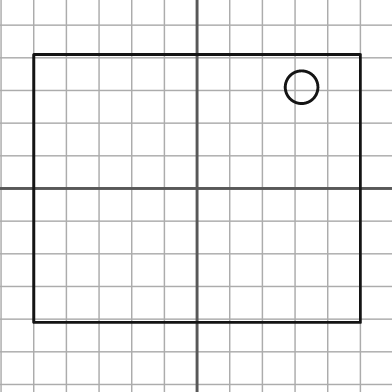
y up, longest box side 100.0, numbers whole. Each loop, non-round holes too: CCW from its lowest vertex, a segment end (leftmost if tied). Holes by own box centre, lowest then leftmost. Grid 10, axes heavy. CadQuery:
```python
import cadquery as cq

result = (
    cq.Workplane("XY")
    .moveTo(-50.0, -41.0)
    .lineTo(50.0, -41.0)
    .lineTo(50.0, 41.0)
    .lineTo(-50.0, 41.0)
    .close()
    .moveTo(32.0, 31.0)
    .circle(5.0)
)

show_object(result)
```